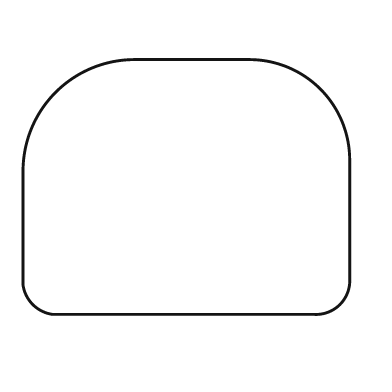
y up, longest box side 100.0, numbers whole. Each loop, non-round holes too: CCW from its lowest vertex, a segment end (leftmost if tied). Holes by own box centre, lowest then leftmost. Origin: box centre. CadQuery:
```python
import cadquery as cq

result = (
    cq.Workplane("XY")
    .moveTo(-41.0, -39.0)
    .lineTo(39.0, -39.0)
    .threePointArc((47.0, -36.0), (50.0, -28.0))
    .lineTo(50.0, 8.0)
    .threePointArc((41.0, 30.0), (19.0, 39.0))
    .lineTo(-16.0, 39.0)
    .threePointArc((-40.0, 29.0), (-50.0, 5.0))
    .lineTo(-50.0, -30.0)
    .threePointArc((-47.0, -36.0), (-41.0, -39.0))
    .close()
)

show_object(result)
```